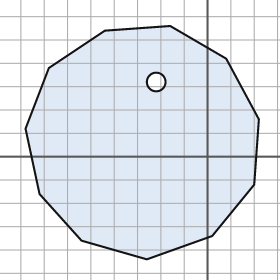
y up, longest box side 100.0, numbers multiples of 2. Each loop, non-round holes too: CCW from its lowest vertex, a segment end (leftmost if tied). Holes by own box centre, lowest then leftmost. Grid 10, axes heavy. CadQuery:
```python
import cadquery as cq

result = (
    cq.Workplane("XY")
    .moveTo(-26.0, -44.0)
    .lineTo(2.0, -34.0)
    .lineTo(20.0, -12.0)
    .lineTo(22.0, 16.0)
    .lineTo(8.0, 42.0)
    .lineTo(-16.0, 56.0)
    .lineTo(-44.0, 54.0)
    .lineTo(-68.0, 38.0)
    .lineTo(-78.0, 12.0)
    .lineTo(-72.0, -16.0)
    .lineTo(-54.0, -36.0)
    .close()
    .moveTo(-22.0, 32.0)
    .circle(4.0)
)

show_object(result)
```